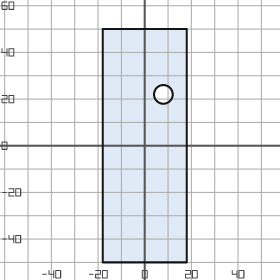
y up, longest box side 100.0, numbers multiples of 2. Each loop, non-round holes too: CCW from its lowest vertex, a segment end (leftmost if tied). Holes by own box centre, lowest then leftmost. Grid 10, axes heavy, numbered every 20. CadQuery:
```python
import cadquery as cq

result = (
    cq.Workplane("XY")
    .moveTo(-18.0, -50.0)
    .lineTo(18.0, -50.0)
    .lineTo(18.0, 50.0)
    .lineTo(-18.0, 50.0)
    .close()
    .moveTo(8.0, 22.0)
    .circle(4.0)
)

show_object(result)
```